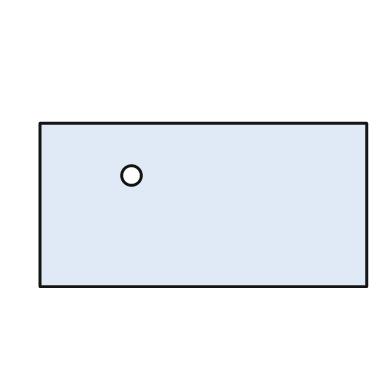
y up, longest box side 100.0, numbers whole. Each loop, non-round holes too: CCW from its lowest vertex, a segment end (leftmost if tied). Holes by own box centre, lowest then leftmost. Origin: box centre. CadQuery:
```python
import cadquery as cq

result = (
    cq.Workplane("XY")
    .moveTo(-50.0, -25.0)
    .lineTo(50.0, -25.0)
    .lineTo(50.0, 25.0)
    .lineTo(-50.0, 25.0)
    .close()
    .moveTo(-22.0, 9.0)
    .circle(3.0)
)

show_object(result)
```